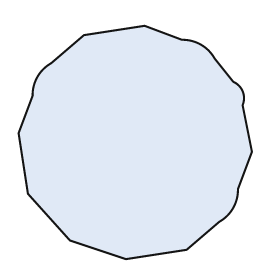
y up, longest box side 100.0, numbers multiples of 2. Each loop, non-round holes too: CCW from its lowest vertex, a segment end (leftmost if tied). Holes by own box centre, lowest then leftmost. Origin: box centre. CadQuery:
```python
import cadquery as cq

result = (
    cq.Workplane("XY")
    .moveTo(-4.0, -50.0)
    .lineTo(22.0, -46.0)
    .lineTo(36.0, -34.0)
    .threePointArc((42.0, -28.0), (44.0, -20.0))
    .lineTo(50.0, -4.0)
    .lineTo(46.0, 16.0)
    .threePointArc((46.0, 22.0), (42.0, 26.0))
    .lineTo(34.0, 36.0)
    .threePointArc((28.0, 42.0), (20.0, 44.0))
    .lineTo(4.0, 50.0)
    .lineTo(-22.0, 46.0)
    .lineTo(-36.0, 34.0)
    .threePointArc((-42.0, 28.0), (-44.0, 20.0))
    .lineTo(-50.0, 4.0)
    .lineTo(-46.0, -22.0)
    .lineTo(-28.0, -42.0)
    .close()
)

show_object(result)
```